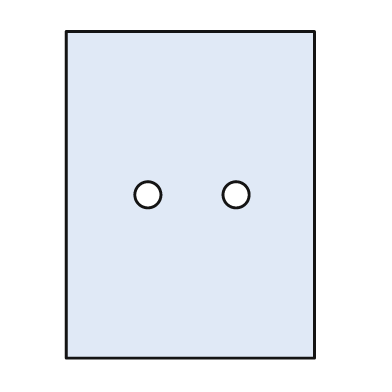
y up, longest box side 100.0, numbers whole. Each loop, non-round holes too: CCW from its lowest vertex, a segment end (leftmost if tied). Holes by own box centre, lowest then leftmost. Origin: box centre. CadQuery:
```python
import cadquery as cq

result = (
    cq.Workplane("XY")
    .moveTo(-38.0, -50.0)
    .lineTo(38.0, -50.0)
    .lineTo(38.0, 50.0)
    .lineTo(-38.0, 50.0)
    .close()
    .moveTo(-13.0, 0.0)
    .circle(4.0)
    .moveTo(14.0, 0.0)
    .circle(4.0)
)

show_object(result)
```